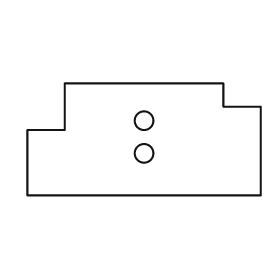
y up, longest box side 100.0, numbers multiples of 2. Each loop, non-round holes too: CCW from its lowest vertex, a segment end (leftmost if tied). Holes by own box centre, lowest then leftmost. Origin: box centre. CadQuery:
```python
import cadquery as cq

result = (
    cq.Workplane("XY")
    .moveTo(-50.0, -24.0)
    .lineTo(50.0, -24.0)
    .lineTo(50.0, 14.0)
    .lineTo(34.0, 14.0)
    .lineTo(34.0, 24.0)
    .lineTo(-34.0, 24.0)
    .lineTo(-34.0, 4.0)
    .lineTo(-50.0, 4.0)
    .close()
    .moveTo(0.0, -6.0)
    .circle(4.0)
    .moveTo(0.0, 8.0)
    .circle(4.0)
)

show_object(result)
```